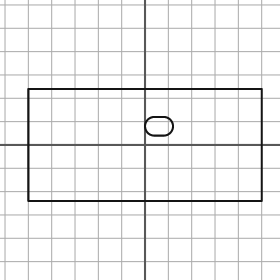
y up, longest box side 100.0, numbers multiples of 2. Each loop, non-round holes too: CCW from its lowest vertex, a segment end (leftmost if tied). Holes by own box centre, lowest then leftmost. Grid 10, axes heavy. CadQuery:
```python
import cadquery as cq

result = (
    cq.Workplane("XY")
    .moveTo(-50.0, -24.0)
    .lineTo(50.0, -24.0)
    .lineTo(50.0, 24.0)
    .lineTo(-50.0, 24.0)
    .close()
    .moveTo(4.0, 4.0)
    .lineTo(8.0, 4.0)
    .threePointArc((12.0, 8.0), (8.0, 12.0))
    .lineTo(4.0, 12.0)
    .threePointArc((0.0, 8.0), (4.0, 4.0))
    .close()
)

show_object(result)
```